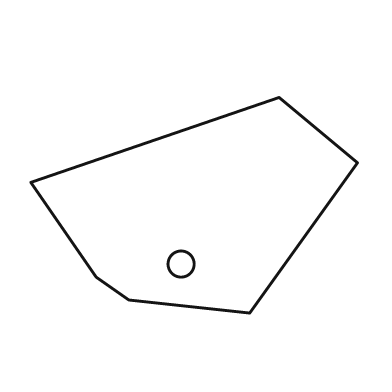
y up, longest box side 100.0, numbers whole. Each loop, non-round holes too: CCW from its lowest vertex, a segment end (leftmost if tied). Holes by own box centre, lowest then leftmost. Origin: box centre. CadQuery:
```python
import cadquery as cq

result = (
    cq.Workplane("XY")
    .moveTo(17.0, -33.0)
    .lineTo(50.0, 13.0)
    .lineTo(26.0, 33.0)
    .lineTo(-50.0, 7.0)
    .lineTo(-30.0, -22.0)
    .lineTo(-20.0, -29.0)
    .close()
    .moveTo(-4.0, -18.0)
    .circle(4.0)
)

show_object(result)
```